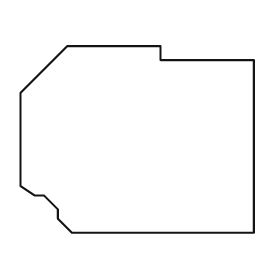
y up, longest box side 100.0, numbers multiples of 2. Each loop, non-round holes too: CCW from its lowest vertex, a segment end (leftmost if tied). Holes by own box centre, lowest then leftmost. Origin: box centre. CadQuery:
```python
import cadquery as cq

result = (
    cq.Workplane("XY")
    .moveTo(-28.0, -40.0)
    .lineTo(50.0, -40.0)
    .lineTo(50.0, 34.0)
    .lineTo(10.0, 34.0)
    .lineTo(10.0, 40.0)
    .lineTo(-30.0, 40.0)
    .lineTo(-50.0, 20.0)
    .lineTo(-50.0, -20.0)
    .lineTo(-44.0, -24.0)
    .lineTo(-40.0, -24.0)
    .lineTo(-34.0, -30.0)
    .lineTo(-34.0, -34.0)
    .close()
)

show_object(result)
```